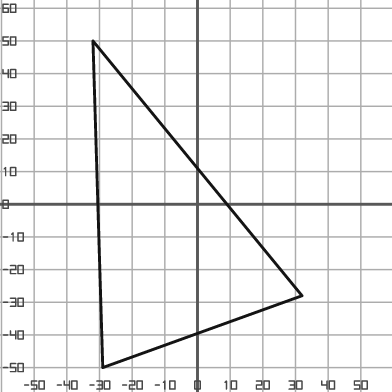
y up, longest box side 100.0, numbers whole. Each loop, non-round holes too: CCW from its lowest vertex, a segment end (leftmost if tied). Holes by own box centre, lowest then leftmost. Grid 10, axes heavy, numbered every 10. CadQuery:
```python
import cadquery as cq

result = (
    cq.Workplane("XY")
    .moveTo(-29.0, -50.0)
    .lineTo(32.0, -28.0)
    .lineTo(-32.0, 50.0)
    .close()
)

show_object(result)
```